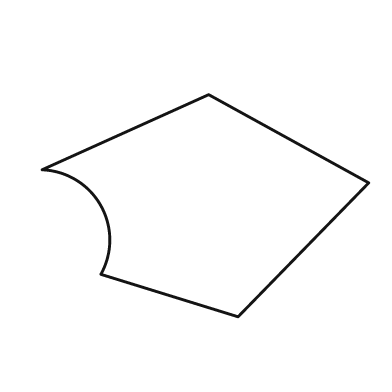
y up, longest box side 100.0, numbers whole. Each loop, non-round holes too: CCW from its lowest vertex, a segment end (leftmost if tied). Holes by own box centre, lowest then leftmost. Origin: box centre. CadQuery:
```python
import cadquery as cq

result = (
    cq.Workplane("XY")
    .moveTo(10.0, -34.0)
    .lineTo(50.0, 7.0)
    .lineTo(1.0, 34.0)
    .lineTo(-50.0, 11.0)
    .threePointArc((-32.0, 0.0), (-32.0, -21.0))
    .close()
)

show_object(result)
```